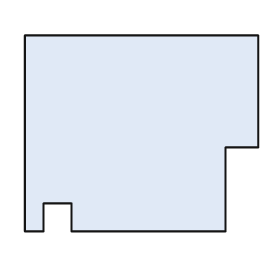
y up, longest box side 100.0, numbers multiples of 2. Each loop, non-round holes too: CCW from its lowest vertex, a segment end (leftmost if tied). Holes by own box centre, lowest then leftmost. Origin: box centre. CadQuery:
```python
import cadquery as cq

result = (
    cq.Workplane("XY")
    .moveTo(-50.0, -42.0)
    .lineTo(-42.0, -42.0)
    .lineTo(-42.0, -30.0)
    .lineTo(-30.0, -30.0)
    .lineTo(-30.0, -42.0)
    .lineTo(36.0, -42.0)
    .lineTo(36.0, -6.0)
    .lineTo(50.0, -6.0)
    .lineTo(50.0, 42.0)
    .lineTo(-50.0, 42.0)
    .close()
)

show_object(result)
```